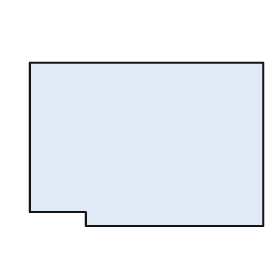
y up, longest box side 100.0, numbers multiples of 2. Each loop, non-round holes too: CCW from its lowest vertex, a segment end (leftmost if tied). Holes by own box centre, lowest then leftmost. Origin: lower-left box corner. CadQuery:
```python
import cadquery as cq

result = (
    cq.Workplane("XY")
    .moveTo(24.0, 0.0)
    .lineTo(100.0, 0.0)
    .lineTo(100.0, 70.0)
    .lineTo(0.0, 70.0)
    .lineTo(0.0, 6.0)
    .lineTo(24.0, 6.0)
    .close()
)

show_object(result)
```